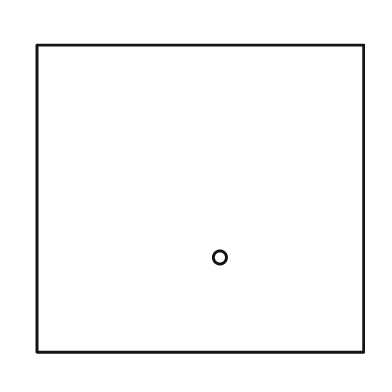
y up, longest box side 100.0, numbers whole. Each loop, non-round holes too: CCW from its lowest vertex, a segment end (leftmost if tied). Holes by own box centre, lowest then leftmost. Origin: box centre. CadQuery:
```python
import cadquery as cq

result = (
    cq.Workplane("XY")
    .moveTo(-50.0, -47.0)
    .lineTo(50.0, -47.0)
    .lineTo(50.0, 47.0)
    .lineTo(-50.0, 47.0)
    .close()
    .moveTo(6.0, -18.0)
    .circle(2.0)
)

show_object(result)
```